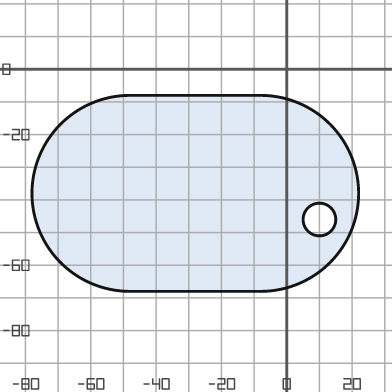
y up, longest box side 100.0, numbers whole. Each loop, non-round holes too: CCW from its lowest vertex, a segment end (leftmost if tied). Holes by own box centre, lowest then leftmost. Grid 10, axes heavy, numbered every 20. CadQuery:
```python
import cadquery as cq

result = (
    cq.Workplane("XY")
    .moveTo(-48.0, -68.0)
    .lineTo(-8.0, -68.0)
    .threePointArc((22.0, -38.0), (-8.0, -8.0))
    .lineTo(-48.0, -8.0)
    .threePointArc((-78.0, -38.0), (-48.0, -68.0))
    .close()
    .moveTo(10.0, -46.0)
    .circle(5.0)
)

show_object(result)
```